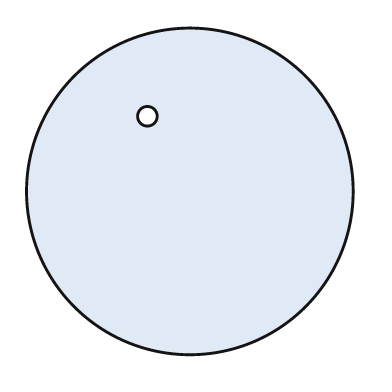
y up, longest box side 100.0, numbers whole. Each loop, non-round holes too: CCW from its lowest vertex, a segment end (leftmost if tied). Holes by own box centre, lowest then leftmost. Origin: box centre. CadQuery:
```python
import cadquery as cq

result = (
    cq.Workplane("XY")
    .moveTo(0.0, 0.0)
    .circle(50.0)
    .moveTo(-13.0, 23.0)
    .circle(3.0)
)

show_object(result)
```